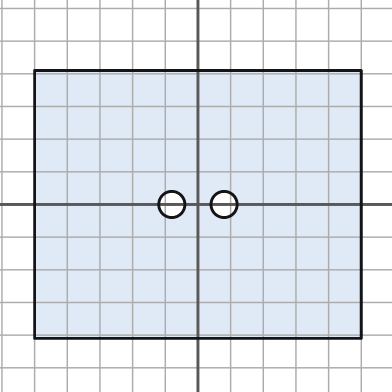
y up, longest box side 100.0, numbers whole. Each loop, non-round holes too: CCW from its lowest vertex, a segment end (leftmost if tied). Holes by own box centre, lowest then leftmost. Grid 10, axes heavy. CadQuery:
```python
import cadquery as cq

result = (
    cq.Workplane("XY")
    .moveTo(-50.0, -41.0)
    .lineTo(50.0, -41.0)
    .lineTo(50.0, 41.0)
    .lineTo(-50.0, 41.0)
    .close()
    .moveTo(-8.0, 0.0)
    .circle(4.0)
    .moveTo(8.0, 0.0)
    .circle(4.0)
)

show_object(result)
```